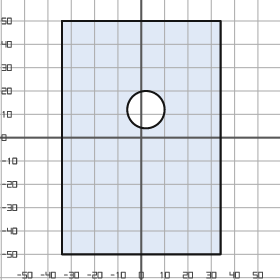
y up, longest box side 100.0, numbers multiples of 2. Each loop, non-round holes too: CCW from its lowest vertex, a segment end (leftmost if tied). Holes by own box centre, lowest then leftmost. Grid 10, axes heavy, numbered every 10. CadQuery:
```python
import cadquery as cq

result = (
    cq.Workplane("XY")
    .moveTo(-34.0, -50.0)
    .lineTo(34.0, -50.0)
    .lineTo(34.0, 50.0)
    .lineTo(-34.0, 50.0)
    .close()
    .moveTo(2.0, 12.0)
    .circle(8.0)
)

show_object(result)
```